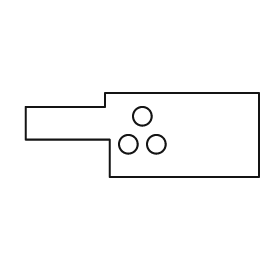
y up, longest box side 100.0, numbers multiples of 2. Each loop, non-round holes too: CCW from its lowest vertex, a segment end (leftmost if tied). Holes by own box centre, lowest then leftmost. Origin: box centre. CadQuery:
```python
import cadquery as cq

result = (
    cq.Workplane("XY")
    .moveTo(-14.0, -18.0)
    .lineTo(50.0, -18.0)
    .lineTo(50.0, 18.0)
    .lineTo(-16.0, 18.0)
    .lineTo(-16.0, 12.0)
    .lineTo(-50.0, 12.0)
    .lineTo(-50.0, -2.0)
    .lineTo(-14.0, -2.0)
    .close()
    .moveTo(-6.0, -4.0)
    .circle(4.0)
    .moveTo(6.0, -4.0)
    .circle(4.0)
    .moveTo(0.0, 8.0)
    .circle(4.0)
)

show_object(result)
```